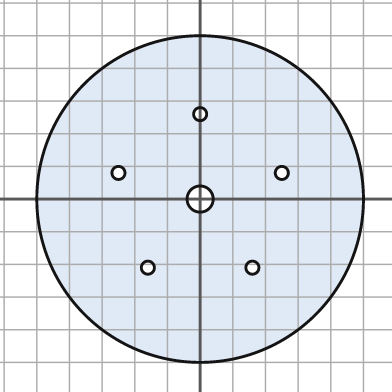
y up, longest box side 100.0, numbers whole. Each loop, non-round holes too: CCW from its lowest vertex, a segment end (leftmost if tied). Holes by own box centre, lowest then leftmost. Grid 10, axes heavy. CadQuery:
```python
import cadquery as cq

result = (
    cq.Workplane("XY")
    .moveTo(0.0, 0.0)
    .circle(50.0)
    .moveTo(-16.0, -21.0)
    .circle(2.0)
    .moveTo(16.0, -21.0)
    .circle(2.0)
    .moveTo(0.0, 0.0)
    .circle(4.0)
    .moveTo(-25.0, 8.0)
    .circle(2.0)
    .moveTo(25.0, 8.0)
    .circle(2.0)
    .moveTo(0.0, 26.0)
    .circle(2.0)
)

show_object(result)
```